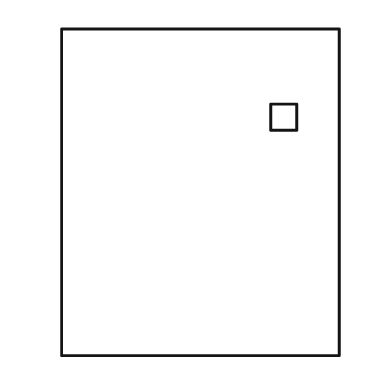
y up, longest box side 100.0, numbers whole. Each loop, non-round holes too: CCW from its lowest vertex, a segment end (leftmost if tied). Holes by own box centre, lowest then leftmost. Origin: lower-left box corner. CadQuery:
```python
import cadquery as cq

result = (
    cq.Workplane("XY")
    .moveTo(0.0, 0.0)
    .lineTo(85.0, 0.0)
    .lineTo(85.0, 100.0)
    .lineTo(0.0, 100.0)
    .close()
    .moveTo(64.0, 69.0)
    .lineTo(72.0, 69.0)
    .lineTo(72.0, 77.0)
    .lineTo(64.0, 77.0)
    .close()
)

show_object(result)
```